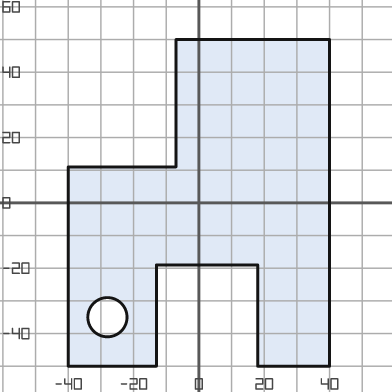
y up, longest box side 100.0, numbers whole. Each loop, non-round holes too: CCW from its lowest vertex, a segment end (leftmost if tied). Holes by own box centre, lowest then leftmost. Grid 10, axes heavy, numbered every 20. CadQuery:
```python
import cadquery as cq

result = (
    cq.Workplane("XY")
    .moveTo(-40.0, -50.0)
    .lineTo(-13.0, -50.0)
    .lineTo(-13.0, -19.0)
    .lineTo(18.0, -19.0)
    .lineTo(18.0, -50.0)
    .lineTo(40.0, -50.0)
    .lineTo(40.0, 50.0)
    .lineTo(-7.0, 50.0)
    .lineTo(-7.0, 11.0)
    .lineTo(-40.0, 11.0)
    .close()
    .moveTo(-28.0, -35.0)
    .circle(6.0)
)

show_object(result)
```